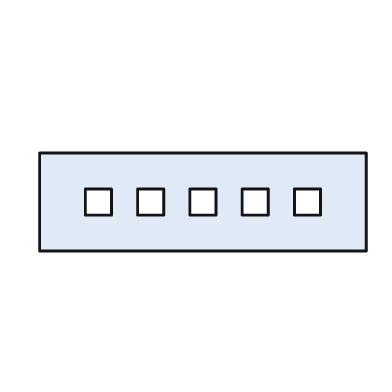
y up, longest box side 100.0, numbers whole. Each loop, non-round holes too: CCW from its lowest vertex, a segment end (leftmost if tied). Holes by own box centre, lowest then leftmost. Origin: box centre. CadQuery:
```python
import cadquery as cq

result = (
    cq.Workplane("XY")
    .moveTo(-50.0, -15.0)
    .lineTo(50.0, -15.0)
    .lineTo(50.0, 15.0)
    .lineTo(-50.0, 15.0)
    .close()
    .moveTo(-36.0, -4.0)
    .lineTo(-28.0, -4.0)
    .lineTo(-28.0, 4.0)
    .lineTo(-36.0, 4.0)
    .close()
    .moveTo(-20.0, -4.0)
    .lineTo(-12.0, -4.0)
    .lineTo(-12.0, 4.0)
    .lineTo(-20.0, 4.0)
    .close()
    .moveTo(-4.0, -4.0)
    .lineTo(4.0, -4.0)
    .lineTo(4.0, 4.0)
    .lineTo(-4.0, 4.0)
    .close()
    .moveTo(12.0, -4.0)
    .lineTo(20.0, -4.0)
    .lineTo(20.0, 4.0)
    .lineTo(12.0, 4.0)
    .close()
    .moveTo(28.0, -4.0)
    .lineTo(36.0, -4.0)
    .lineTo(36.0, 4.0)
    .lineTo(28.0, 4.0)
    .close()
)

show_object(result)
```